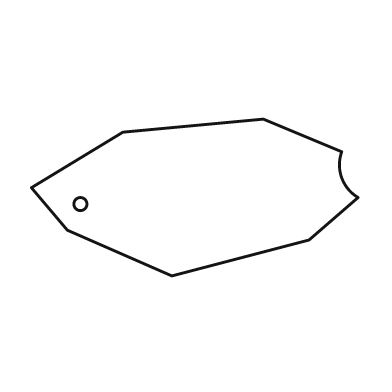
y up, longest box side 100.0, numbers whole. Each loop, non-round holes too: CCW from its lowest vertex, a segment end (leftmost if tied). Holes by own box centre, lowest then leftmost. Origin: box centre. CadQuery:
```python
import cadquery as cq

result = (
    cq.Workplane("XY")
    .moveTo(-7.0, -24.0)
    .lineTo(35.0, -13.0)
    .lineTo(50.0, 0.0)
    .threePointArc((45.0, 6.0), (45.0, 14.0))
    .lineTo(21.0, 24.0)
    .lineTo(-22.0, 20.0)
    .lineTo(-50.0, 3.0)
    .lineTo(-39.0, -10.0)
    .close()
    .moveTo(-35.0, -2.0)
    .circle(2.0)
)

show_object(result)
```